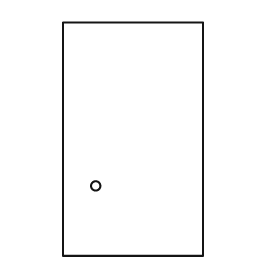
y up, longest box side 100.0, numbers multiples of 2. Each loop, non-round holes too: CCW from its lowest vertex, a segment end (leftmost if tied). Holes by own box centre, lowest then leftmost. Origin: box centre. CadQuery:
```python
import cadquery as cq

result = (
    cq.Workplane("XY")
    .moveTo(-30.0, -50.0)
    .lineTo(30.0, -50.0)
    .lineTo(30.0, 50.0)
    .lineTo(-30.0, 50.0)
    .close()
    .moveTo(-16.0, -20.0)
    .circle(2.0)
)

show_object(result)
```